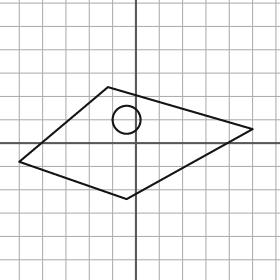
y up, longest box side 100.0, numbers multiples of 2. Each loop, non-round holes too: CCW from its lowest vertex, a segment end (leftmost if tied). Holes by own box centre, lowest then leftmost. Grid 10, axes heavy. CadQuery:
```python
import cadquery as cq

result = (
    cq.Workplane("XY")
    .moveTo(-4.0, -24.0)
    .lineTo(50.0, 6.0)
    .lineTo(-12.0, 24.0)
    .lineTo(-50.0, -8.0)
    .close()
    .moveTo(-4.0, 10.0)
    .circle(6.0)
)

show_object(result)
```